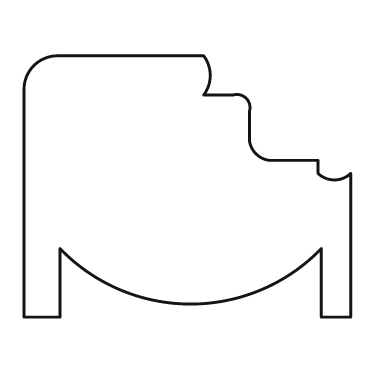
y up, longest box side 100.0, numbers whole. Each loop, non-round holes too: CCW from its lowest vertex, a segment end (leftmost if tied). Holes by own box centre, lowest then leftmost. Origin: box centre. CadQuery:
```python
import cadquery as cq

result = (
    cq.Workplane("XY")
    .moveTo(-50.0, -40.0)
    .lineTo(-39.0, -40.0)
    .lineTo(-39.0, -19.0)
    .threePointArc((1.0, -36.0), (41.0, -19.0))
    .lineTo(41.0, -40.0)
    .lineTo(50.0, -40.0)
    .lineTo(50.0, 4.0)
    .threePointArc((45.0, 2.0), (40.0, 4.0))
    .lineTo(40.0, 8.0)
    .lineTo(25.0, 8.0)
    .threePointArc((21.0, 10.0), (19.0, 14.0))
    .lineTo(19.0, 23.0)
    .threePointArc((18.0, 27.0), (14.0, 28.0))
    .lineTo(5.0, 28.0)
    .threePointArc((7.0, 34.0), (5.0, 40.0))
    .lineTo(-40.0, 40.0)
    .threePointArc((-47.0, 37.0), (-50.0, 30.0))
    .close()
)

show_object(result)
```